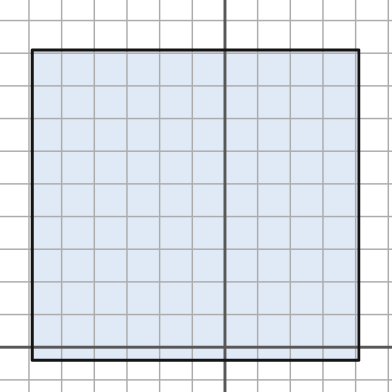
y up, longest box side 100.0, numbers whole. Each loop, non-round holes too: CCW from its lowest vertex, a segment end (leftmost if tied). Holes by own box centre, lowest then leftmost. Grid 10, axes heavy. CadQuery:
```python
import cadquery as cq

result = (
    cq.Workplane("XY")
    .moveTo(-59.0, -4.0)
    .lineTo(41.0, -4.0)
    .lineTo(41.0, 91.0)
    .lineTo(-59.0, 91.0)
    .close()
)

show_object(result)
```